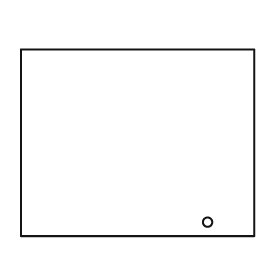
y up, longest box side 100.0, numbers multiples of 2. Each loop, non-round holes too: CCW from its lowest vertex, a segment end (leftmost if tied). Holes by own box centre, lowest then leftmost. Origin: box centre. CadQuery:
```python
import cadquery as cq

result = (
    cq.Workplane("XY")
    .moveTo(-50.0, -40.0)
    .lineTo(50.0, -40.0)
    .lineTo(50.0, 40.0)
    .lineTo(-50.0, 40.0)
    .close()
    .moveTo(30.0, -34.0)
    .circle(2.0)
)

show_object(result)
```